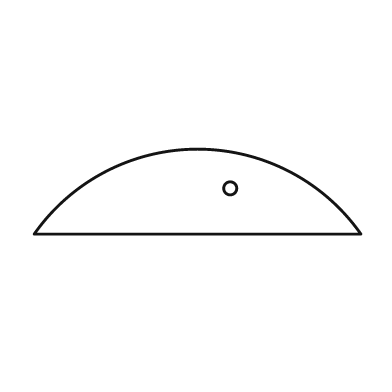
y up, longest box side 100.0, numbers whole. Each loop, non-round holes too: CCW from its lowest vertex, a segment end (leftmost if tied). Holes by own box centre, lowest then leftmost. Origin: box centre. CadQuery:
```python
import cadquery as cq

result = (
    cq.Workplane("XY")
    .moveTo(-50.0, -13.0)
    .lineTo(50.0, -13.0)
    .threePointArc((0.0, 13.0), (-50.0, -13.0))
    .close()
    .moveTo(10.0, 1.0)
    .circle(2.0)
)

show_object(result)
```